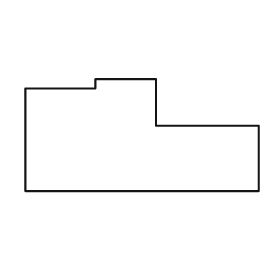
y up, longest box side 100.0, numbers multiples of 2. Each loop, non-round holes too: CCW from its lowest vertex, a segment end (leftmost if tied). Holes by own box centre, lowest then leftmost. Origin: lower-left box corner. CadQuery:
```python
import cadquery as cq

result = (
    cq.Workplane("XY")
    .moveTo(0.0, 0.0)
    .lineTo(100.0, 0.0)
    .lineTo(100.0, 28.0)
    .lineTo(56.0, 28.0)
    .lineTo(56.0, 48.0)
    .lineTo(30.0, 48.0)
    .lineTo(30.0, 44.0)
    .lineTo(0.0, 44.0)
    .close()
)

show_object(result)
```